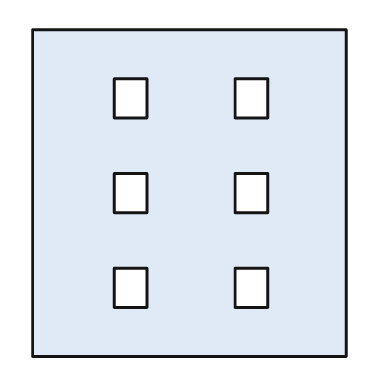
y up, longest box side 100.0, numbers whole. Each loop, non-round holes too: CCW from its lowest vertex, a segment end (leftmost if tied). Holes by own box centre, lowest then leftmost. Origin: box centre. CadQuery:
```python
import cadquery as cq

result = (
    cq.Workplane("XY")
    .moveTo(-48.0, -50.0)
    .lineTo(48.0, -50.0)
    .lineTo(48.0, 50.0)
    .lineTo(-48.0, 50.0)
    .close()
    .moveTo(-23.0, -35.0)
    .lineTo(-13.0, -35.0)
    .lineTo(-13.0, -23.0)
    .lineTo(-23.0, -23.0)
    .close()
    .moveTo(14.0, -35.0)
    .lineTo(24.0, -35.0)
    .lineTo(24.0, -23.0)
    .lineTo(14.0, -23.0)
    .close()
    .moveTo(-23.0, -6.0)
    .lineTo(-13.0, -6.0)
    .lineTo(-13.0, 6.0)
    .lineTo(-23.0, 6.0)
    .close()
    .moveTo(14.0, -6.0)
    .lineTo(24.0, -6.0)
    .lineTo(24.0, 6.0)
    .lineTo(14.0, 6.0)
    .close()
    .moveTo(-23.0, 23.0)
    .lineTo(-13.0, 23.0)
    .lineTo(-13.0, 35.0)
    .lineTo(-23.0, 35.0)
    .close()
    .moveTo(14.0, 23.0)
    .lineTo(24.0, 23.0)
    .lineTo(24.0, 35.0)
    .lineTo(14.0, 35.0)
    .close()
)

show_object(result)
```